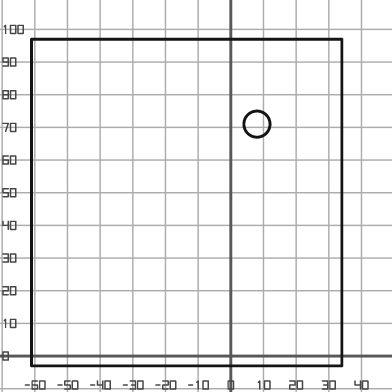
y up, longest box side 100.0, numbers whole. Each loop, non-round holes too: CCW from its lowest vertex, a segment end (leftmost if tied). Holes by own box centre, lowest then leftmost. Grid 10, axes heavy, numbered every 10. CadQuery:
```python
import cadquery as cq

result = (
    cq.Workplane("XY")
    .moveTo(-61.0, -3.0)
    .lineTo(34.0, -3.0)
    .lineTo(34.0, 97.0)
    .lineTo(-61.0, 97.0)
    .close()
    .moveTo(8.0, 71.0)
    .circle(4.0)
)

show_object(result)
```